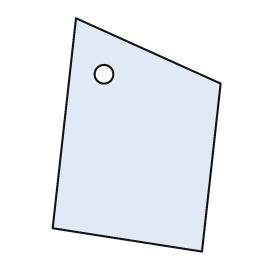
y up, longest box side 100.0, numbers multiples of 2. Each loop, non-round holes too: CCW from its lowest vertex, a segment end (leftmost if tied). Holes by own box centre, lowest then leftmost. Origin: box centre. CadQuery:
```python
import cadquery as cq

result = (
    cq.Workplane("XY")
    .moveTo(28.0, -50.0)
    .lineTo(36.0, 22.0)
    .lineTo(-26.0, 50.0)
    .lineTo(-36.0, -40.0)
    .close()
    .moveTo(-14.0, 26.0)
    .circle(4.0)
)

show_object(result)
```